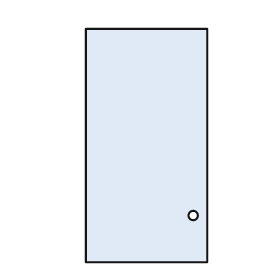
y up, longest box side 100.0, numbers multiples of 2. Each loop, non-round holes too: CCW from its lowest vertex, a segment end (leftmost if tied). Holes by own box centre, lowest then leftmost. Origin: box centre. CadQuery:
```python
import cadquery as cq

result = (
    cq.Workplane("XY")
    .moveTo(-26.0, -50.0)
    .lineTo(26.0, -50.0)
    .lineTo(26.0, 50.0)
    .lineTo(-26.0, 50.0)
    .close()
    .moveTo(20.0, -30.0)
    .circle(2.0)
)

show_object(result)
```